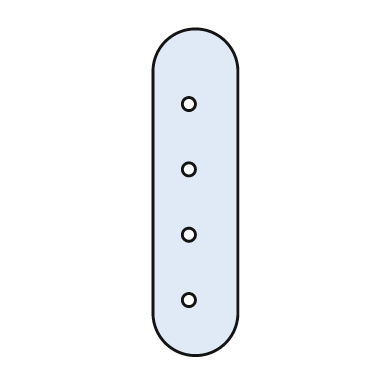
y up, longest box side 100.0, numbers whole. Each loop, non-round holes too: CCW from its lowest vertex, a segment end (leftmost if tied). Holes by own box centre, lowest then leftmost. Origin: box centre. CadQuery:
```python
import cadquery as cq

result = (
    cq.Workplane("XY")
    .moveTo(-13.0, -37.0)
    .threePointArc((0.0, -50.0), (13.0, -37.0))
    .lineTo(13.0, 37.0)
    .threePointArc((0.0, 50.0), (-13.0, 37.0))
    .close()
    .moveTo(-2.0, -33.0)
    .circle(2.0)
    .moveTo(-2.0, -13.0)
    .circle(2.0)
    .moveTo(-2.0, 7.0)
    .circle(2.0)
    .moveTo(-2.0, 27.0)
    .circle(2.0)
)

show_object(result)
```